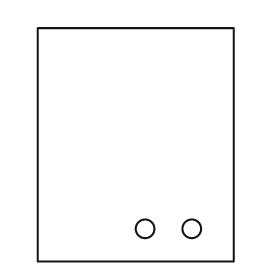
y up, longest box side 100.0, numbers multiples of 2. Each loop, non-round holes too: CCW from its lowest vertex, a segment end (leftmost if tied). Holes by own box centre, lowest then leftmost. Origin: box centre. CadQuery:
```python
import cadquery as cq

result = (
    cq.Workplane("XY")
    .moveTo(-42.0, -50.0)
    .lineTo(42.0, -50.0)
    .lineTo(42.0, 50.0)
    .lineTo(-42.0, 50.0)
    .close()
    .moveTo(4.0, -36.0)
    .circle(4.0)
    .moveTo(24.0, -36.0)
    .circle(4.0)
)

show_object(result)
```